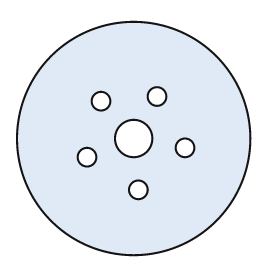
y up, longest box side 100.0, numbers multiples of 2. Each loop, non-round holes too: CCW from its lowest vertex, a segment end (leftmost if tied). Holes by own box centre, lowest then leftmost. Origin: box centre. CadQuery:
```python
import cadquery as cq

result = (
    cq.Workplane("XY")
    .moveTo(0.0, 0.0)
    .circle(50.0)
    .moveTo(2.0, -22.0)
    .circle(4.0)
    .moveTo(-20.0, -8.0)
    .circle(4.0)
    .moveTo(22.0, -4.0)
    .circle(4.0)
    .moveTo(0.0, 0.0)
    .circle(8.0)
    .moveTo(-14.0, 16.0)
    .circle(4.0)
    .moveTo(10.0, 18.0)
    .circle(4.0)
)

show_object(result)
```